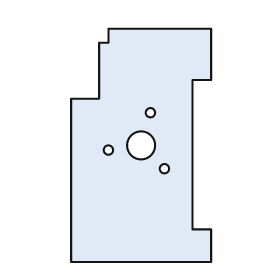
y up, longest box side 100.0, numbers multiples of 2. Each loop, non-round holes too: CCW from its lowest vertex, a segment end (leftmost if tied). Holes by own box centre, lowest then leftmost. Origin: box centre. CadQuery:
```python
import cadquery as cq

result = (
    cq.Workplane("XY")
    .moveTo(-30.0, -50.0)
    .lineTo(30.0, -50.0)
    .lineTo(30.0, -36.0)
    .lineTo(22.0, -36.0)
    .lineTo(22.0, 28.0)
    .lineTo(30.0, 28.0)
    .lineTo(30.0, 50.0)
    .lineTo(-14.0, 50.0)
    .lineTo(-14.0, 44.0)
    .lineTo(-18.0, 44.0)
    .lineTo(-18.0, 20.0)
    .lineTo(-30.0, 20.0)
    .close()
    .moveTo(10.0, -10.0)
    .circle(2.0)
    .moveTo(-14.0, -2.0)
    .circle(2.0)
    .moveTo(0.0, 0.0)
    .circle(6.0)
    .moveTo(4.0, 14.0)
    .circle(2.0)
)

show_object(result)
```